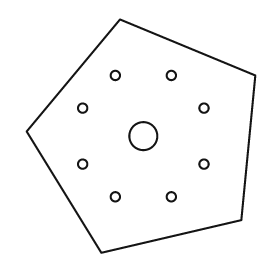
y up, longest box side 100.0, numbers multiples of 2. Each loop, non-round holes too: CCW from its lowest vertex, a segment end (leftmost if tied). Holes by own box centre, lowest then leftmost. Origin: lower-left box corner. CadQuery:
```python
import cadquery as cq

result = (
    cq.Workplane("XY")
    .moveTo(32.0, 0.0)
    .lineTo(92.0, 14.0)
    .lineTo(98.0, 76.0)
    .lineTo(40.0, 100.0)
    .lineTo(0.0, 52.0)
    .close()
    .moveTo(38.0, 24.0)
    .circle(2.0)
    .moveTo(62.0, 24.0)
    .circle(2.0)
    .moveTo(24.0, 38.0)
    .circle(2.0)
    .moveTo(76.0, 38.0)
    .circle(2.0)
    .moveTo(50.0, 50.0)
    .circle(6.0)
    .moveTo(24.0, 62.0)
    .circle(2.0)
    .moveTo(76.0, 62.0)
    .circle(2.0)
    .moveTo(38.0, 76.0)
    .circle(2.0)
    .moveTo(62.0, 76.0)
    .circle(2.0)
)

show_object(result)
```